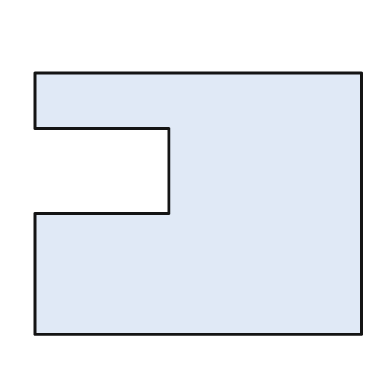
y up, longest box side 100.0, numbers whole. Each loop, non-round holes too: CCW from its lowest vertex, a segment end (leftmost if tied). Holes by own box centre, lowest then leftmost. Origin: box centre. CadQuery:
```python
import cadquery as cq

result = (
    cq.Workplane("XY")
    .moveTo(-50.0, -40.0)
    .lineTo(50.0, -40.0)
    .lineTo(50.0, 40.0)
    .lineTo(-50.0, 40.0)
    .lineTo(-50.0, 23.0)
    .lineTo(-9.0, 23.0)
    .lineTo(-9.0, -3.0)
    .lineTo(-50.0, -3.0)
    .close()
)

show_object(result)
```